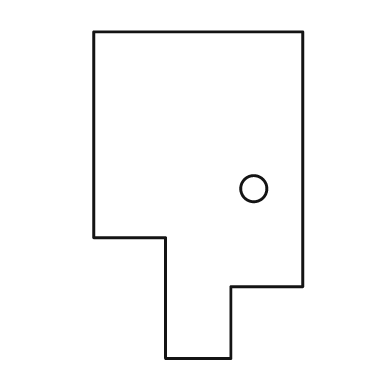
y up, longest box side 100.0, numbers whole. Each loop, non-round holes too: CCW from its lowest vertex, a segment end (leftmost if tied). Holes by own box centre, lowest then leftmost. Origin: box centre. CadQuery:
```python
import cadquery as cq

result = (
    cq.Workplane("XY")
    .moveTo(-10.0, -50.0)
    .lineTo(10.0, -50.0)
    .lineTo(10.0, -28.0)
    .lineTo(32.0, -28.0)
    .lineTo(32.0, 50.0)
    .lineTo(-32.0, 50.0)
    .lineTo(-32.0, -13.0)
    .lineTo(-10.0, -13.0)
    .close()
    .moveTo(17.0, 2.0)
    .circle(4.0)
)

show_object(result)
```